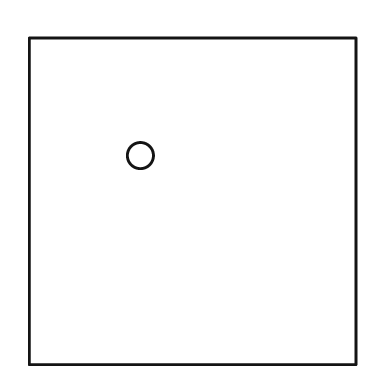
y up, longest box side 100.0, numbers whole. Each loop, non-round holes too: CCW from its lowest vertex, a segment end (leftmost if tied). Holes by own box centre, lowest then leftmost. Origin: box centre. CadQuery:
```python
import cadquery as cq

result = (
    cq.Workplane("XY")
    .moveTo(-50.0, -50.0)
    .lineTo(50.0, -50.0)
    .lineTo(50.0, 50.0)
    .lineTo(-50.0, 50.0)
    .close()
    .moveTo(-16.0, 14.0)
    .circle(4.0)
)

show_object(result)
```